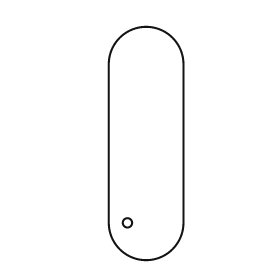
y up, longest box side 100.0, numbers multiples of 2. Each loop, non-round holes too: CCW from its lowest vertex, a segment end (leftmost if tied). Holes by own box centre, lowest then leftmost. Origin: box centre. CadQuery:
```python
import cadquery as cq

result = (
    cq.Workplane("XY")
    .moveTo(-16.0, -34.0)
    .threePointArc((0.0, -50.0), (16.0, -34.0))
    .lineTo(16.0, 34.0)
    .threePointArc((0.0, 50.0), (-16.0, 34.0))
    .close()
    .moveTo(-8.0, -34.0)
    .circle(2.0)
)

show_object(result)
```